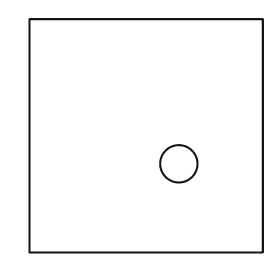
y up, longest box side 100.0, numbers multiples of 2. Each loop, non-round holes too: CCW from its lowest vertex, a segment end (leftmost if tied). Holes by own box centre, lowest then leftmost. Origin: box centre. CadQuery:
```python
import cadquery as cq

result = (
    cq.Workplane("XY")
    .moveTo(-50.0, -50.0)
    .lineTo(50.0, -50.0)
    .lineTo(50.0, 50.0)
    .lineTo(-50.0, 50.0)
    .close()
    .moveTo(14.0, -12.0)
    .circle(8.0)
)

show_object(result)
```